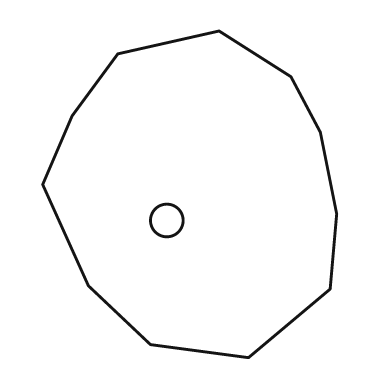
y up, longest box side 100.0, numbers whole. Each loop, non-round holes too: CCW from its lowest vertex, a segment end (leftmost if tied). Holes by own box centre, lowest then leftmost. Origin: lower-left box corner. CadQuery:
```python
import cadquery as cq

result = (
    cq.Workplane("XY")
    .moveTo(63.0, 0.0)
    .lineTo(88.0, 21.0)
    .lineTo(90.0, 44.0)
    .lineTo(85.0, 69.0)
    .lineTo(76.0, 86.0)
    .lineTo(54.0, 100.0)
    .lineTo(23.0, 93.0)
    .lineTo(9.0, 74.0)
    .lineTo(0.0, 53.0)
    .lineTo(14.0, 22.0)
    .lineTo(33.0, 4.0)
    .close()
    .moveTo(38.0, 42.0)
    .circle(5.0)
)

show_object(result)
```